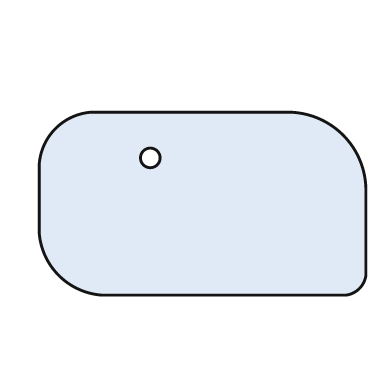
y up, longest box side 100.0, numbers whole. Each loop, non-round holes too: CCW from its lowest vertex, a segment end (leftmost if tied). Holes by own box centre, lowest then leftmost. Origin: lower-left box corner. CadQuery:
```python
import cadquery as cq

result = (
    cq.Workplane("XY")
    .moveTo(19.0, 0.0)
    .lineTo(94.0, 0.0)
    .threePointArc((98.0, 2.0), (100.0, 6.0))
    .lineTo(100.0, 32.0)
    .threePointArc((93.0, 49.0), (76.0, 56.0))
    .lineTo(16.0, 56.0)
    .threePointArc((5.0, 51.0), (0.0, 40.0))
    .lineTo(0.0, 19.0)
    .threePointArc((6.0, 6.0), (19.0, 0.0))
    .close()
    .moveTo(34.0, 42.0)
    .circle(3.0)
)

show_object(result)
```